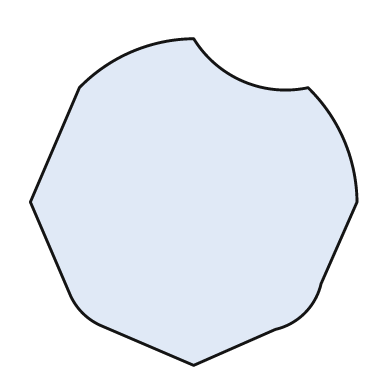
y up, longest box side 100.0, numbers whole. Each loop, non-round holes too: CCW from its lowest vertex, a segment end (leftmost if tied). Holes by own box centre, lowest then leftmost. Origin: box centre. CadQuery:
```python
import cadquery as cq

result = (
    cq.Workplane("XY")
    .moveTo(0.0, -50.0)
    .lineTo(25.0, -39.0)
    .threePointArc((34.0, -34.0), (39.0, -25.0))
    .lineTo(50.0, 0.0)
    .threePointArc((46.0, 19.0), (35.0, 35.0))
    .threePointArc((15.0, 37.0), (0.0, 50.0))
    .threePointArc((-19.0, 46.0), (-35.0, 35.0))
    .lineTo(-50.0, 0.0)
    .lineTo(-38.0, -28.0)
    .threePointArc((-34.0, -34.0), (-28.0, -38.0))
    .close()
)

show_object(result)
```